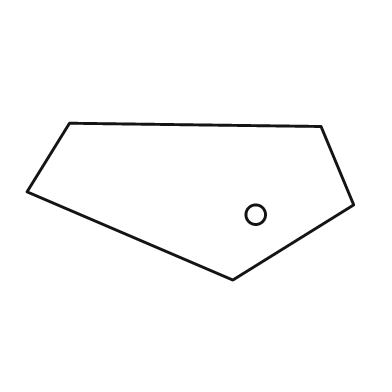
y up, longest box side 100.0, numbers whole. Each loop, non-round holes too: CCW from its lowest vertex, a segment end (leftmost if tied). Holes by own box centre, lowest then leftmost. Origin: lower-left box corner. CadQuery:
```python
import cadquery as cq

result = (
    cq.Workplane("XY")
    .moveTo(63.0, 0.0)
    .lineTo(100.0, 23.0)
    .lineTo(90.0, 47.0)
    .lineTo(13.0, 48.0)
    .lineTo(0.0, 27.0)
    .close()
    .moveTo(70.0, 20.0)
    .circle(3.0)
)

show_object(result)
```